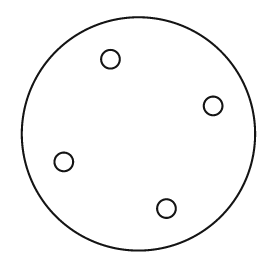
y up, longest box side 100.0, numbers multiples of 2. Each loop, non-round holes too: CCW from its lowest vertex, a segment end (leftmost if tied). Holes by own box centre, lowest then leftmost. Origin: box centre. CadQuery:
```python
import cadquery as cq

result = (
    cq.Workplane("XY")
    .moveTo(0.0, 0.0)
    .circle(50.0)
    .moveTo(12.0, -32.0)
    .circle(4.0)
    .moveTo(-32.0, -12.0)
    .circle(4.0)
    .moveTo(32.0, 12.0)
    .circle(4.0)
    .moveTo(-12.0, 32.0)
    .circle(4.0)
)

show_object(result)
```